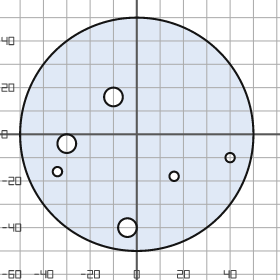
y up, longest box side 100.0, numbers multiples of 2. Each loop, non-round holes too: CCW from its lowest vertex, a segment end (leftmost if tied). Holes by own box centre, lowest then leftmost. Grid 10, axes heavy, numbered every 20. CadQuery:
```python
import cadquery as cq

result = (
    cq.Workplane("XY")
    .moveTo(0.0, 0.0)
    .circle(50.0)
    .moveTo(-4.0, -40.0)
    .circle(4.0)
    .moveTo(16.0, -18.0)
    .circle(2.0)
    .moveTo(-34.0, -16.0)
    .circle(2.0)
    .moveTo(40.0, -10.0)
    .circle(2.0)
    .moveTo(-30.0, -4.0)
    .circle(4.0)
    .moveTo(-10.0, 16.0)
    .circle(4.0)
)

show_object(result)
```